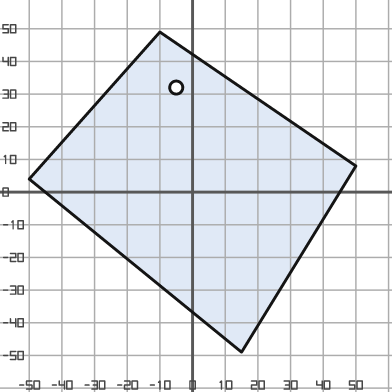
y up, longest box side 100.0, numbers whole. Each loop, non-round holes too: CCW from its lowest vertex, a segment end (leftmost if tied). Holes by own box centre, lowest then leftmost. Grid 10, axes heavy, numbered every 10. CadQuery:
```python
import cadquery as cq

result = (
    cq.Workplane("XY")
    .moveTo(15.0, -49.0)
    .lineTo(50.0, 8.0)
    .lineTo(-10.0, 49.0)
    .lineTo(-50.0, 4.0)
    .close()
    .moveTo(-5.0, 32.0)
    .circle(2.0)
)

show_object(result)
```